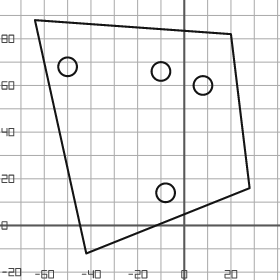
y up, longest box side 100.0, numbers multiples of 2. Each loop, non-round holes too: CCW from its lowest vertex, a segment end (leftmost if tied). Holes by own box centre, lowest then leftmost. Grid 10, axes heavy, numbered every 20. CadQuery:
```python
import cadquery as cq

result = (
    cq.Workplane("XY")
    .moveTo(-42.0, -12.0)
    .lineTo(28.0, 16.0)
    .lineTo(20.0, 82.0)
    .lineTo(-64.0, 88.0)
    .close()
    .moveTo(-8.0, 14.0)
    .circle(4.0)
    .moveTo(8.0, 60.0)
    .circle(4.0)
    .moveTo(-10.0, 66.0)
    .circle(4.0)
    .moveTo(-50.0, 68.0)
    .circle(4.0)
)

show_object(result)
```